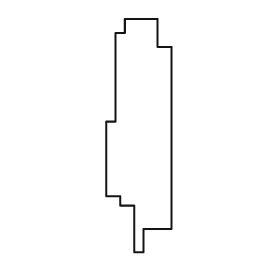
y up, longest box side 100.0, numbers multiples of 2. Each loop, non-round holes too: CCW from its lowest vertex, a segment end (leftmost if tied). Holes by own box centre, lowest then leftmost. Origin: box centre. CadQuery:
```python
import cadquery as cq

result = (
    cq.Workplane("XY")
    .moveTo(-2.0, -50.0)
    .lineTo(2.0, -50.0)
    .lineTo(2.0, -40.0)
    .lineTo(14.0, -40.0)
    .lineTo(14.0, 38.0)
    .lineTo(8.0, 38.0)
    .lineTo(8.0, 50.0)
    .lineTo(-6.0, 50.0)
    .lineTo(-6.0, 44.0)
    .lineTo(-10.0, 44.0)
    .lineTo(-10.0, 6.0)
    .lineTo(-14.0, 6.0)
    .lineTo(-14.0, -26.0)
    .lineTo(-8.0, -26.0)
    .lineTo(-8.0, -30.0)
    .lineTo(-2.0, -30.0)
    .close()
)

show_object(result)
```